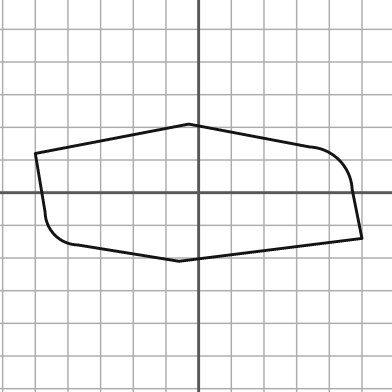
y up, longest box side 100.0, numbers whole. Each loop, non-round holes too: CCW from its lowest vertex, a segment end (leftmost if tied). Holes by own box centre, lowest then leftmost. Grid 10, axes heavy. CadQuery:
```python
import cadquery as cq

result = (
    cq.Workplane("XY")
    .moveTo(-6.0, -21.0)
    .lineTo(50.0, -14.0)
    .lineTo(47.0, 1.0)
    .threePointArc((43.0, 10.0), (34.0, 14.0))
    .lineTo(-3.0, 21.0)
    .lineTo(-50.0, 12.0)
    .lineTo(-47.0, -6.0)
    .threePointArc((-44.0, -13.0), (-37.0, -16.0))
    .close()
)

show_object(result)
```